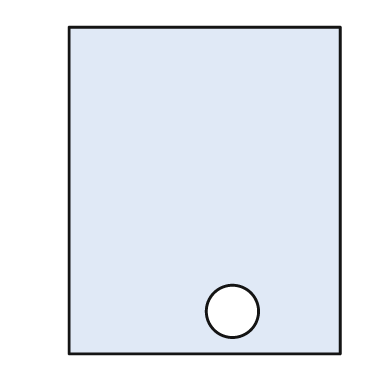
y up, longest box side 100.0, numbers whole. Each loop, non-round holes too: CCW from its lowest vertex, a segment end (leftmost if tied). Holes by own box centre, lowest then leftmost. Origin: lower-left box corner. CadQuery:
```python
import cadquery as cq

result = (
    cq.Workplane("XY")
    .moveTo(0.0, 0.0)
    .lineTo(83.0, 0.0)
    .lineTo(83.0, 100.0)
    .lineTo(0.0, 100.0)
    .close()
    .moveTo(50.0, 13.0)
    .circle(8.0)
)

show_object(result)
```